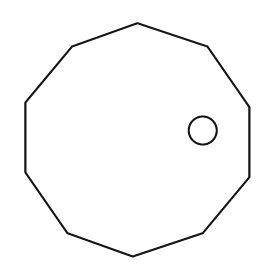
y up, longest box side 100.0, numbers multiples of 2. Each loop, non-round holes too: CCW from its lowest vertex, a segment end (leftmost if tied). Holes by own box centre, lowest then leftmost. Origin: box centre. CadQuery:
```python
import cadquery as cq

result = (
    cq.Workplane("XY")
    .moveTo(-2.0, -50.0)
    .lineTo(28.0, -40.0)
    .lineTo(48.0, -16.0)
    .lineTo(48.0, 14.0)
    .lineTo(30.0, 40.0)
    .lineTo(0.0, 50.0)
    .lineTo(-28.0, 40.0)
    .lineTo(-48.0, 16.0)
    .lineTo(-48.0, -14.0)
    .lineTo(-30.0, -40.0)
    .close()
    .moveTo(28.0, 4.0)
    .circle(6.0)
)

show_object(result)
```